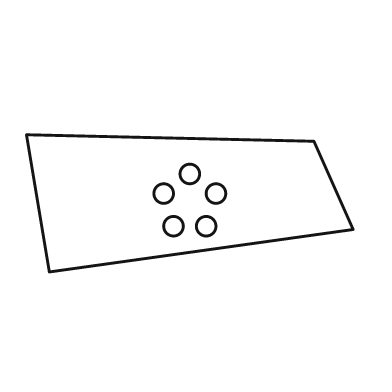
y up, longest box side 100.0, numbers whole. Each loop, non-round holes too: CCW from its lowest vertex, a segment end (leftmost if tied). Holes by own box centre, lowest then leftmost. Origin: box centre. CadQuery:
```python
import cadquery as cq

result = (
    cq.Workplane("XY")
    .moveTo(-43.0, -21.0)
    .lineTo(50.0, -8.0)
    .lineTo(38.0, 19.0)
    .lineTo(-50.0, 21.0)
    .close()
    .moveTo(-5.0, -7.0)
    .circle(3.0)
    .moveTo(5.0, -7.0)
    .circle(3.0)
    .moveTo(-8.0, 3.0)
    .circle(3.0)
    .moveTo(8.0, 3.0)
    .circle(3.0)
    .moveTo(0.0, 9.0)
    .circle(3.0)
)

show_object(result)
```